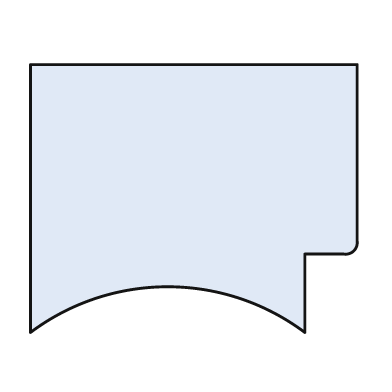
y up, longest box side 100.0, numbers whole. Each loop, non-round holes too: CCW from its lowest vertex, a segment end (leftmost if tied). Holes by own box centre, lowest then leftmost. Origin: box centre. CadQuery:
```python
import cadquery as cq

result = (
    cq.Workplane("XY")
    .moveTo(-50.0, -41.0)
    .threePointArc((-8.0, -27.0), (34.0, -41.0))
    .lineTo(34.0, -17.0)
    .lineTo(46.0, -17.0)
    .threePointArc((49.0, -16.0), (50.0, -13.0))
    .lineTo(50.0, 41.0)
    .lineTo(-50.0, 41.0)
    .close()
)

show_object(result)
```